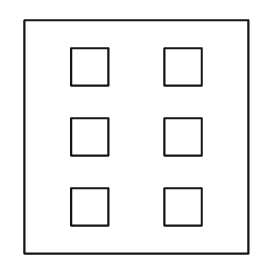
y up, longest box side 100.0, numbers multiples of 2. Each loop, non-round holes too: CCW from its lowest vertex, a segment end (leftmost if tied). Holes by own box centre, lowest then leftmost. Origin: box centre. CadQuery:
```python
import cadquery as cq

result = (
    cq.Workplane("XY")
    .moveTo(-48.0, -50.0)
    .lineTo(48.0, -50.0)
    .lineTo(48.0, 50.0)
    .lineTo(-48.0, 50.0)
    .close()
    .moveTo(-28.0, -38.0)
    .lineTo(-12.0, -38.0)
    .lineTo(-12.0, -22.0)
    .lineTo(-28.0, -22.0)
    .close()
    .moveTo(12.0, -38.0)
    .lineTo(28.0, -38.0)
    .lineTo(28.0, -22.0)
    .lineTo(12.0, -22.0)
    .close()
    .moveTo(-28.0, -8.0)
    .lineTo(-12.0, -8.0)
    .lineTo(-12.0, 8.0)
    .lineTo(-28.0, 8.0)
    .close()
    .moveTo(12.0, -8.0)
    .lineTo(28.0, -8.0)
    .lineTo(28.0, 8.0)
    .lineTo(12.0, 8.0)
    .close()
    .moveTo(-28.0, 22.0)
    .lineTo(-12.0, 22.0)
    .lineTo(-12.0, 38.0)
    .lineTo(-28.0, 38.0)
    .close()
    .moveTo(12.0, 22.0)
    .lineTo(28.0, 22.0)
    .lineTo(28.0, 38.0)
    .lineTo(12.0, 38.0)
    .close()
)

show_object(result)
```